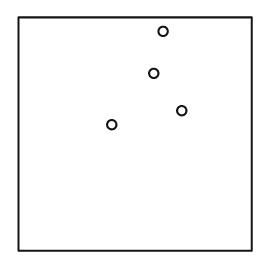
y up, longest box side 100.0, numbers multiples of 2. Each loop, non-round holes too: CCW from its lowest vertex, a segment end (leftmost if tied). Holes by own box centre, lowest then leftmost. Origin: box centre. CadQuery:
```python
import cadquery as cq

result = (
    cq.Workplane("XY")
    .moveTo(-50.0, -50.0)
    .lineTo(50.0, -50.0)
    .lineTo(50.0, 50.0)
    .lineTo(-50.0, 50.0)
    .close()
    .moveTo(-10.0, 4.0)
    .circle(2.0)
    .moveTo(20.0, 10.0)
    .circle(2.0)
    .moveTo(8.0, 26.0)
    .circle(2.0)
    .moveTo(12.0, 44.0)
    .circle(2.0)
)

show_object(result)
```